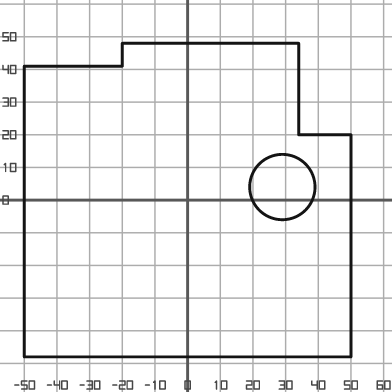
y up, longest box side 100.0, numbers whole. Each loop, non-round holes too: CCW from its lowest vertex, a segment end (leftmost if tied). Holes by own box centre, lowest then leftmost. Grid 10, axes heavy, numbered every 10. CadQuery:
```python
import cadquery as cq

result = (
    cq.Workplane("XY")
    .moveTo(-50.0, -48.0)
    .lineTo(50.0, -48.0)
    .lineTo(50.0, 20.0)
    .lineTo(34.0, 20.0)
    .lineTo(34.0, 48.0)
    .lineTo(-20.0, 48.0)
    .lineTo(-20.0, 41.0)
    .lineTo(-50.0, 41.0)
    .close()
    .moveTo(29.0, 4.0)
    .circle(10.0)
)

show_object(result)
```